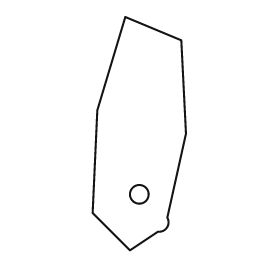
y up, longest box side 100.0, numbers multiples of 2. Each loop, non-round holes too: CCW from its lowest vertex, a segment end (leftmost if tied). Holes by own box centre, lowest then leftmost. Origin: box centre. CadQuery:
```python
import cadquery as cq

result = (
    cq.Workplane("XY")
    .moveTo(-4.0, -50.0)
    .lineTo(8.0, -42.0)
    .threePointArc((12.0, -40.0), (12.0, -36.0))
    .lineTo(20.0, 0.0)
    .lineTo(18.0, 40.0)
    .lineTo(-6.0, 50.0)
    .lineTo(-18.0, 10.0)
    .lineTo(-20.0, -34.0)
    .close()
    .moveTo(0.0, -26.0)
    .circle(4.0)
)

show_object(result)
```